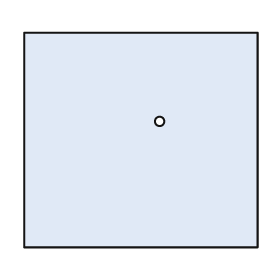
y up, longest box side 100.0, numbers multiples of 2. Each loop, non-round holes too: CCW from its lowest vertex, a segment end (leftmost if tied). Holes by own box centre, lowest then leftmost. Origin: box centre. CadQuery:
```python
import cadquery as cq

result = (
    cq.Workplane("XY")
    .moveTo(-50.0, -46.0)
    .lineTo(50.0, -46.0)
    .lineTo(50.0, 46.0)
    .lineTo(-50.0, 46.0)
    .close()
    .moveTo(8.0, 8.0)
    .circle(2.0)
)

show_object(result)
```